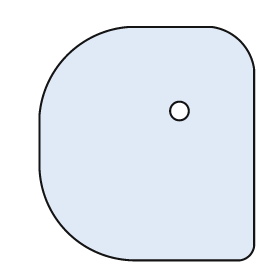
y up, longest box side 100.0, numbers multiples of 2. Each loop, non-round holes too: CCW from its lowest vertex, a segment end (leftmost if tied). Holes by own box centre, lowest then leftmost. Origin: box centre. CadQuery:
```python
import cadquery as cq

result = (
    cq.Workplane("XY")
    .moveTo(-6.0, -50.0)
    .lineTo(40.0, -50.0)
    .threePointArc((44.0, -48.0), (46.0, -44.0))
    .lineTo(46.0, 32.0)
    .threePointArc((40.0, 44.0), (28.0, 50.0))
    .lineTo(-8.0, 50.0)
    .threePointArc((-34.0, 38.0), (-46.0, 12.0))
    .lineTo(-46.0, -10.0)
    .threePointArc((-34.0, -38.0), (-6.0, -50.0))
    .close()
    .moveTo(14.0, 14.0)
    .circle(4.0)
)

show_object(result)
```